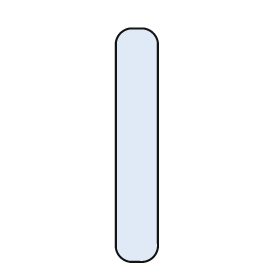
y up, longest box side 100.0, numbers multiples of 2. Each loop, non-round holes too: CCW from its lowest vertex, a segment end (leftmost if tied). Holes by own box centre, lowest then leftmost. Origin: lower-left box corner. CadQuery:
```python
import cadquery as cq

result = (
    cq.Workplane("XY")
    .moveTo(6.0, 0.0)
    .lineTo(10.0, 0.0)
    .threePointArc((16.0, 2.0), (18.0, 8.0))
    .lineTo(18.0, 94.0)
    .threePointArc((16.0, 98.0), (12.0, 100.0))
    .lineTo(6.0, 100.0)
    .threePointArc((2.0, 98.0), (0.0, 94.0))
    .lineTo(0.0, 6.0)
    .threePointArc((2.0, 2.0), (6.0, 0.0))
    .close()
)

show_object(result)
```